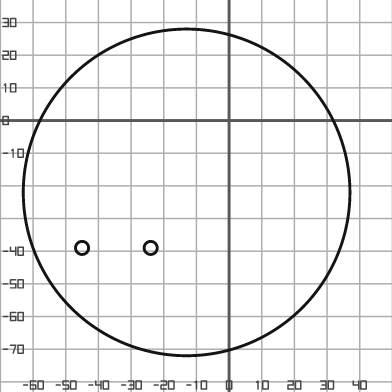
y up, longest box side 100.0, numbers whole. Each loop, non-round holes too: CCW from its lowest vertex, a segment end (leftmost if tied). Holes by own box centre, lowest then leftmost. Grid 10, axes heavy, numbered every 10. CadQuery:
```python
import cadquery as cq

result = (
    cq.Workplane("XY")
    .moveTo(-13.0, -22.0)
    .circle(50.0)
    .moveTo(-45.0, -39.0)
    .circle(2.0)
    .moveTo(-24.0, -39.0)
    .circle(2.0)
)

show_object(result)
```